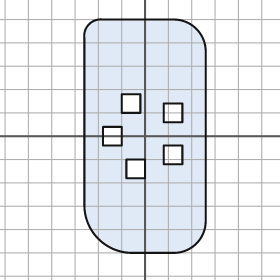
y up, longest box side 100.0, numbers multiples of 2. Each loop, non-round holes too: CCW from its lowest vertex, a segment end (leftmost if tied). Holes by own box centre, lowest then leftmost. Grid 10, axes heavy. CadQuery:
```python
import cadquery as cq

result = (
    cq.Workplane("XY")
    .moveTo(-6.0, -50.0)
    .lineTo(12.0, -50.0)
    .threePointArc((22.0, -46.0), (26.0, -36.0))
    .lineTo(26.0, 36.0)
    .threePointArc((22.0, 46.0), (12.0, 50.0))
    .lineTo(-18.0, 50.0)
    .threePointArc((-24.0, 48.0), (-26.0, 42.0))
    .lineTo(-26.0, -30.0)
    .threePointArc((-20.0, -44.0), (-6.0, -50.0))
    .close()
    .moveTo(-8.0, -18.0)
    .lineTo(0.0, -18.0)
    .lineTo(0.0, -10.0)
    .lineTo(-8.0, -10.0)
    .close()
    .moveTo(8.0, -12.0)
    .lineTo(16.0, -12.0)
    .lineTo(16.0, -4.0)
    .lineTo(8.0, -4.0)
    .close()
    .moveTo(-18.0, -4.0)
    .lineTo(-10.0, -4.0)
    .lineTo(-10.0, 4.0)
    .lineTo(-18.0, 4.0)
    .close()
    .moveTo(8.0, 6.0)
    .lineTo(16.0, 6.0)
    .lineTo(16.0, 14.0)
    .lineTo(8.0, 14.0)
    .close()
    .moveTo(-10.0, 10.0)
    .lineTo(-2.0, 10.0)
    .lineTo(-2.0, 18.0)
    .lineTo(-10.0, 18.0)
    .close()
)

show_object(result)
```